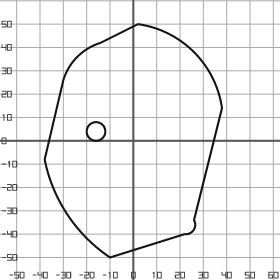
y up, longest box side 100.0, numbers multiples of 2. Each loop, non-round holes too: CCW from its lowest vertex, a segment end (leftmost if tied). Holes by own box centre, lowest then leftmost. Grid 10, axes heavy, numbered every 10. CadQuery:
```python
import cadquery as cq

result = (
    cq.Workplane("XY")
    .moveTo(-10.0, -50.0)
    .lineTo(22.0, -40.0)
    .threePointArc((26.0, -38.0), (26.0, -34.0))
    .lineTo(38.0, 14.0)
    .threePointArc((26.0, 38.0), (2.0, 50.0))
    .lineTo(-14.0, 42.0)
    .threePointArc((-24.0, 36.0), (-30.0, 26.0))
    .lineTo(-38.0, -8.0)
    .threePointArc((-28.0, -32.0), (-10.0, -50.0))
    .close()
    .moveTo(-16.0, 4.0)
    .circle(4.0)
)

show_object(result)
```